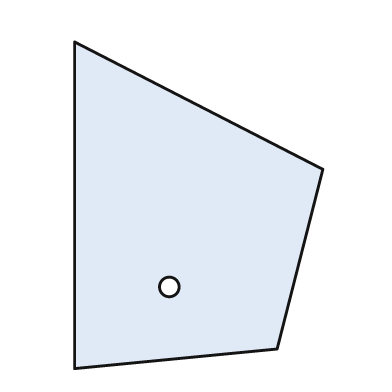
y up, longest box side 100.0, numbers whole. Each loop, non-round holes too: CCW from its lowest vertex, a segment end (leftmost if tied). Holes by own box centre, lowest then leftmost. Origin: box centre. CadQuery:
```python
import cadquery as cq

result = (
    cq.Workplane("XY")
    .moveTo(-38.0, -50.0)
    .lineTo(24.0, -44.0)
    .lineTo(38.0, 11.0)
    .lineTo(-38.0, 50.0)
    .close()
    .moveTo(-9.0, -25.0)
    .circle(3.0)
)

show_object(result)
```